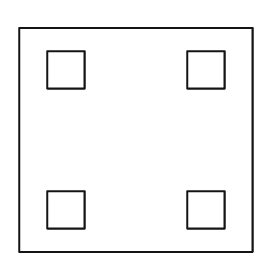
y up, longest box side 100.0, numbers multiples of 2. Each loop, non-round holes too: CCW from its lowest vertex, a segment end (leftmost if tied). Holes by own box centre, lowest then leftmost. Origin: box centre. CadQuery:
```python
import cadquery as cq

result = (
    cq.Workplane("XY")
    .moveTo(-50.0, -48.0)
    .lineTo(50.0, -48.0)
    .lineTo(50.0, 48.0)
    .lineTo(-50.0, 48.0)
    .close()
    .moveTo(-38.0, -38.0)
    .lineTo(-22.0, -38.0)
    .lineTo(-22.0, -22.0)
    .lineTo(-38.0, -22.0)
    .close()
    .moveTo(22.0, -38.0)
    .lineTo(38.0, -38.0)
    .lineTo(38.0, -22.0)
    .lineTo(22.0, -22.0)
    .close()
    .moveTo(-38.0, 22.0)
    .lineTo(-22.0, 22.0)
    .lineTo(-22.0, 38.0)
    .lineTo(-38.0, 38.0)
    .close()
    .moveTo(22.0, 22.0)
    .lineTo(38.0, 22.0)
    .lineTo(38.0, 38.0)
    .lineTo(22.0, 38.0)
    .close()
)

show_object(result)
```